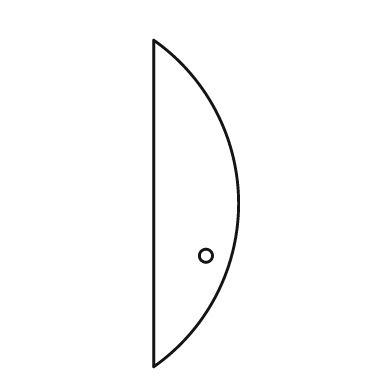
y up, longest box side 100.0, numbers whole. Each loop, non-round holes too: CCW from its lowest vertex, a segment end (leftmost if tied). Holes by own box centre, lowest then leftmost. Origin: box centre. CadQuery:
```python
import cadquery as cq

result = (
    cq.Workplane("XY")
    .moveTo(-13.0, -50.0)
    .threePointArc((13.0, 0.0), (-13.0, 50.0))
    .close()
    .moveTo(3.0, -16.0)
    .circle(2.0)
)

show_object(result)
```